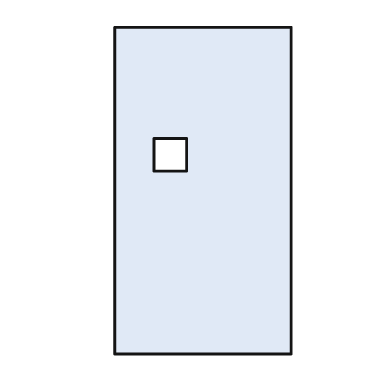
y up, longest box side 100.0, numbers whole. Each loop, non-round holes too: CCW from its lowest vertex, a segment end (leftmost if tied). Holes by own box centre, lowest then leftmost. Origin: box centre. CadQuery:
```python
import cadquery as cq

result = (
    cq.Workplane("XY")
    .moveTo(-27.0, -50.0)
    .lineTo(27.0, -50.0)
    .lineTo(27.0, 50.0)
    .lineTo(-27.0, 50.0)
    .close()
    .moveTo(-15.0, 6.0)
    .lineTo(-5.0, 6.0)
    .lineTo(-5.0, 16.0)
    .lineTo(-15.0, 16.0)
    .close()
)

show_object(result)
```